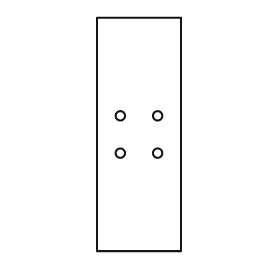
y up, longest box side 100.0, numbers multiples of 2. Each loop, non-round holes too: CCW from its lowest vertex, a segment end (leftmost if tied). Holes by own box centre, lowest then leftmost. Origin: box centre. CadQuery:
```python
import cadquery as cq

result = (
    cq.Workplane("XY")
    .moveTo(-18.0, -50.0)
    .lineTo(18.0, -50.0)
    .lineTo(18.0, 50.0)
    .lineTo(-18.0, 50.0)
    .close()
    .moveTo(-8.0, -8.0)
    .circle(2.0)
    .moveTo(8.0, -8.0)
    .circle(2.0)
    .moveTo(-8.0, 8.0)
    .circle(2.0)
    .moveTo(8.0, 8.0)
    .circle(2.0)
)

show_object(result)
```